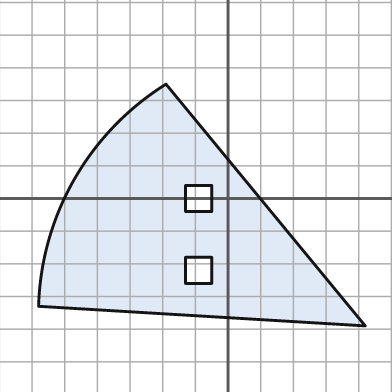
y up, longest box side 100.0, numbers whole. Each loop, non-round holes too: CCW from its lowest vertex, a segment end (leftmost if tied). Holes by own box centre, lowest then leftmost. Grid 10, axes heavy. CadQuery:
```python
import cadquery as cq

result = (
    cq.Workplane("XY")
    .moveTo(42.0, -39.0)
    .lineTo(-19.0, 35.0)
    .threePointArc((-47.0, 6.0), (-58.0, -33.0))
    .close()
    .moveTo(-13.0, -26.0)
    .lineTo(-5.0, -26.0)
    .lineTo(-5.0, -18.0)
    .lineTo(-13.0, -18.0)
    .close()
    .moveTo(-13.0, -4.0)
    .lineTo(-5.0, -4.0)
    .lineTo(-5.0, 4.0)
    .lineTo(-13.0, 4.0)
    .close()
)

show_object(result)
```